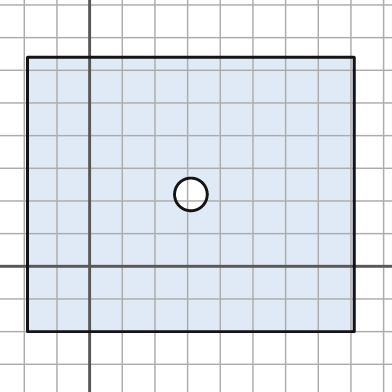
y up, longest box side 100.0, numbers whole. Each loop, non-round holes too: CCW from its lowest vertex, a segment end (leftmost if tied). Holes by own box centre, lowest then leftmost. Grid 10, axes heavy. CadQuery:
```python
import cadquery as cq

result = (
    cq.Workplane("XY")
    .moveTo(-19.0, -20.0)
    .lineTo(81.0, -20.0)
    .lineTo(81.0, 64.0)
    .lineTo(-19.0, 64.0)
    .close()
    .moveTo(31.0, 22.0)
    .circle(5.0)
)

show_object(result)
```